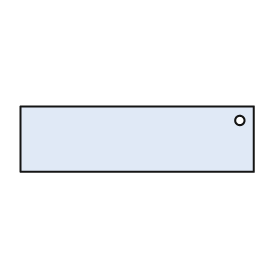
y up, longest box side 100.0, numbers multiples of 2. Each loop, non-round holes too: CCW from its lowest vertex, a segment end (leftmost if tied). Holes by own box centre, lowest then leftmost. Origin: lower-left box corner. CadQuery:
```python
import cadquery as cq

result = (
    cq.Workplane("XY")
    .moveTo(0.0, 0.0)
    .lineTo(100.0, 0.0)
    .lineTo(100.0, 28.0)
    .lineTo(0.0, 28.0)
    .close()
    .moveTo(94.0, 22.0)
    .circle(2.0)
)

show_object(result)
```